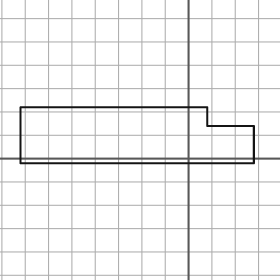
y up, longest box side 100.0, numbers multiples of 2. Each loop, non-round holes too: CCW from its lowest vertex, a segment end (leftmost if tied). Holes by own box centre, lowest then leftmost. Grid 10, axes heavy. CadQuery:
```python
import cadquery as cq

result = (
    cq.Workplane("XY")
    .moveTo(-72.0, -2.0)
    .lineTo(28.0, -2.0)
    .lineTo(28.0, 14.0)
    .lineTo(8.0, 14.0)
    .lineTo(8.0, 22.0)
    .lineTo(-72.0, 22.0)
    .close()
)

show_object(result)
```